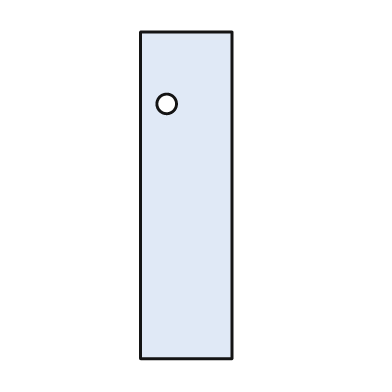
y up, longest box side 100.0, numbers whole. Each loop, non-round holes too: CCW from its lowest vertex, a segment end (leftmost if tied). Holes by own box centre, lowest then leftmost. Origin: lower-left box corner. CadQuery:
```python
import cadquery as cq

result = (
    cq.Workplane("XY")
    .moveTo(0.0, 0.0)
    .lineTo(28.0, 0.0)
    .lineTo(28.0, 100.0)
    .lineTo(0.0, 100.0)
    .close()
    .moveTo(8.0, 78.0)
    .circle(3.0)
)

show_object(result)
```